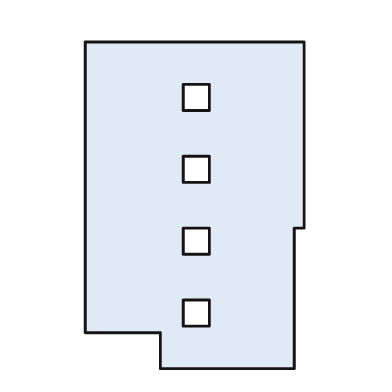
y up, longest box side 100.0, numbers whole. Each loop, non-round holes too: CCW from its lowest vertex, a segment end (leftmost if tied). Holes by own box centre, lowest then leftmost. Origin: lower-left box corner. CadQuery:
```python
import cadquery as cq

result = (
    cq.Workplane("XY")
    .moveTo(23.0, 0.0)
    .lineTo(64.0, 0.0)
    .lineTo(64.0, 43.0)
    .lineTo(67.0, 43.0)
    .lineTo(67.0, 100.0)
    .lineTo(0.0, 100.0)
    .lineTo(0.0, 11.0)
    .lineTo(23.0, 11.0)
    .close()
    .moveTo(30.0, 13.0)
    .lineTo(38.0, 13.0)
    .lineTo(38.0, 21.0)
    .lineTo(30.0, 21.0)
    .close()
    .moveTo(30.0, 35.0)
    .lineTo(38.0, 35.0)
    .lineTo(38.0, 43.0)
    .lineTo(30.0, 43.0)
    .close()
    .moveTo(30.0, 57.0)
    .lineTo(38.0, 57.0)
    .lineTo(38.0, 65.0)
    .lineTo(30.0, 65.0)
    .close()
    .moveTo(30.0, 79.0)
    .lineTo(38.0, 79.0)
    .lineTo(38.0, 87.0)
    .lineTo(30.0, 87.0)
    .close()
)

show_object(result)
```